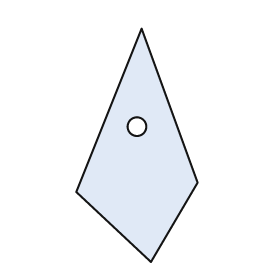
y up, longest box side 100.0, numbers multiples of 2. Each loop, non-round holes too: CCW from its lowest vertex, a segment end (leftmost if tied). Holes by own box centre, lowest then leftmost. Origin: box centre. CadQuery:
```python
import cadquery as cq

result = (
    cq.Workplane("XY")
    .moveTo(6.0, -50.0)
    .lineTo(26.0, -16.0)
    .lineTo(2.0, 50.0)
    .lineTo(-26.0, -20.0)
    .close()
    .moveTo(0.0, 8.0)
    .circle(4.0)
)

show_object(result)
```